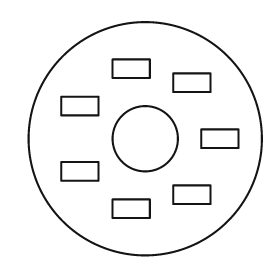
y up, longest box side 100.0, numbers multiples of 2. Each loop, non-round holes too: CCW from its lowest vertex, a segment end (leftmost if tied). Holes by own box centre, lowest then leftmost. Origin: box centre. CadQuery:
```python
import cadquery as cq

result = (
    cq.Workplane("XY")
    .moveTo(0.0, 0.0)
    .circle(50.0)
    .moveTo(-14.0, -34.0)
    .lineTo(2.0, -34.0)
    .lineTo(2.0, -26.0)
    .lineTo(-14.0, -26.0)
    .close()
    .moveTo(12.0, -28.0)
    .lineTo(28.0, -28.0)
    .lineTo(28.0, -20.0)
    .lineTo(12.0, -20.0)
    .close()
    .moveTo(-36.0, -18.0)
    .lineTo(-20.0, -18.0)
    .lineTo(-20.0, -10.0)
    .lineTo(-36.0, -10.0)
    .close()
    .moveTo(0.0, 0.0)
    .circle(14.0)
    .moveTo(24.0, -4.0)
    .lineTo(40.0, -4.0)
    .lineTo(40.0, 4.0)
    .lineTo(24.0, 4.0)
    .close()
    .moveTo(-36.0, 10.0)
    .lineTo(-20.0, 10.0)
    .lineTo(-20.0, 18.0)
    .lineTo(-36.0, 18.0)
    .close()
    .moveTo(12.0, 20.0)
    .lineTo(28.0, 20.0)
    .lineTo(28.0, 28.0)
    .lineTo(12.0, 28.0)
    .close()
    .moveTo(-14.0, 26.0)
    .lineTo(2.0, 26.0)
    .lineTo(2.0, 34.0)
    .lineTo(-14.0, 34.0)
    .close()
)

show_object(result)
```